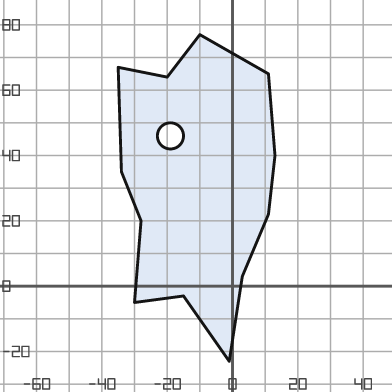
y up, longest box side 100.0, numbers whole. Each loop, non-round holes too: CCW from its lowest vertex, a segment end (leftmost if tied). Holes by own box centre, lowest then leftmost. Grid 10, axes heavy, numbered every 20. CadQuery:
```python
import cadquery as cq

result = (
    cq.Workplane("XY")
    .moveTo(-1.0, -23.0)
    .lineTo(3.0, 3.0)
    .lineTo(11.0, 22.0)
    .lineTo(13.0, 40.0)
    .lineTo(11.0, 65.0)
    .lineTo(-10.0, 77.0)
    .lineTo(-20.0, 64.0)
    .lineTo(-35.0, 67.0)
    .lineTo(-34.0, 35.0)
    .lineTo(-28.0, 20.0)
    .lineTo(-30.0, -5.0)
    .lineTo(-15.0, -3.0)
    .close()
    .moveTo(-19.0, 46.0)
    .circle(4.0)
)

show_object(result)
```